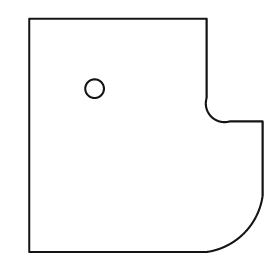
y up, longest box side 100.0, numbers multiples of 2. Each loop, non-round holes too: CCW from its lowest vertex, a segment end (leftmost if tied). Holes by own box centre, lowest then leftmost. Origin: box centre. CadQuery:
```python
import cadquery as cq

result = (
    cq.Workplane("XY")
    .moveTo(-50.0, -50.0)
    .lineTo(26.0, -50.0)
    .threePointArc((42.0, -42.0), (50.0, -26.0))
    .lineTo(50.0, 6.0)
    .lineTo(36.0, 6.0)
    .threePointArc((28.0, 8.0), (26.0, 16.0))
    .lineTo(26.0, 50.0)
    .lineTo(-50.0, 50.0)
    .close()
    .moveTo(-22.0, 20.0)
    .circle(4.0)
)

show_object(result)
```